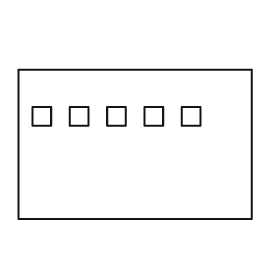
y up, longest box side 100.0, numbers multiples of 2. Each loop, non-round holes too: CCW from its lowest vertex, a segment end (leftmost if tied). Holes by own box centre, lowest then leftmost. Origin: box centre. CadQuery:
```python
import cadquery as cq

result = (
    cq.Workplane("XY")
    .moveTo(-50.0, -32.0)
    .lineTo(50.0, -32.0)
    .lineTo(50.0, 32.0)
    .lineTo(-50.0, 32.0)
    .close()
    .moveTo(-44.0, 8.0)
    .lineTo(-36.0, 8.0)
    .lineTo(-36.0, 16.0)
    .lineTo(-44.0, 16.0)
    .close()
    .moveTo(-28.0, 8.0)
    .lineTo(-20.0, 8.0)
    .lineTo(-20.0, 16.0)
    .lineTo(-28.0, 16.0)
    .close()
    .moveTo(-12.0, 8.0)
    .lineTo(-4.0, 8.0)
    .lineTo(-4.0, 16.0)
    .lineTo(-12.0, 16.0)
    .close()
    .moveTo(4.0, 8.0)
    .lineTo(12.0, 8.0)
    .lineTo(12.0, 16.0)
    .lineTo(4.0, 16.0)
    .close()
    .moveTo(20.0, 8.0)
    .lineTo(28.0, 8.0)
    .lineTo(28.0, 16.0)
    .lineTo(20.0, 16.0)
    .close()
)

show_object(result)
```